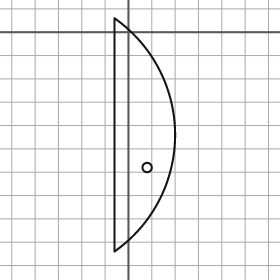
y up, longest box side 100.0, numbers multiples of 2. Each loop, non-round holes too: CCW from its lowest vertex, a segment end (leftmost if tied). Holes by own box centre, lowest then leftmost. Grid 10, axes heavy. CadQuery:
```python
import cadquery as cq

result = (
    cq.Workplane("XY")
    .moveTo(-6.0, -94.0)
    .threePointArc((20.0, -44.0), (-6.0, 6.0))
    .close()
    .moveTo(8.0, -58.0)
    .circle(2.0)
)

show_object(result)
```